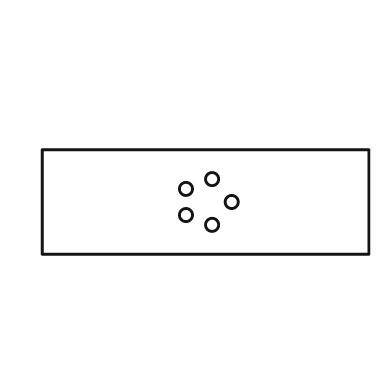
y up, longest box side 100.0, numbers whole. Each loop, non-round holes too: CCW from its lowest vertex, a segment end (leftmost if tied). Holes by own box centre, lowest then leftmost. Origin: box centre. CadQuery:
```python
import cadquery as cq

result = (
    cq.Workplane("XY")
    .moveTo(-50.0, -16.0)
    .lineTo(50.0, -16.0)
    .lineTo(50.0, 16.0)
    .lineTo(-50.0, 16.0)
    .close()
    .moveTo(2.0, -7.0)
    .circle(2.0)
    .moveTo(-6.0, -4.0)
    .circle(2.0)
    .moveTo(8.0, 0.0)
    .circle(2.0)
    .moveTo(-6.0, 4.0)
    .circle(2.0)
    .moveTo(2.0, 7.0)
    .circle(2.0)
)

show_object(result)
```